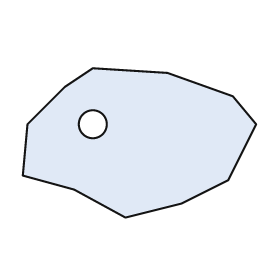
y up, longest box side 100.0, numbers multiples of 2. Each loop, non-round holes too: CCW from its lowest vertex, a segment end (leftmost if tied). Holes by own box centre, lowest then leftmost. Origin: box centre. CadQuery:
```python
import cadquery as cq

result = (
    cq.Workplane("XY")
    .moveTo(-6.0, -32.0)
    .lineTo(18.0, -26.0)
    .lineTo(38.0, -16.0)
    .lineTo(50.0, 8.0)
    .lineTo(40.0, 20.0)
    .lineTo(12.0, 30.0)
    .lineTo(-20.0, 32.0)
    .lineTo(-32.0, 24.0)
    .lineTo(-48.0, 8.0)
    .lineTo(-50.0, -14.0)
    .lineTo(-28.0, -20.0)
    .close()
    .moveTo(-20.0, 8.0)
    .circle(6.0)
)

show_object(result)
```